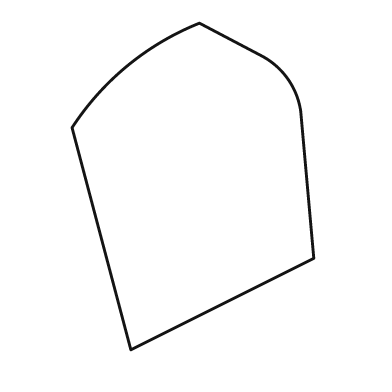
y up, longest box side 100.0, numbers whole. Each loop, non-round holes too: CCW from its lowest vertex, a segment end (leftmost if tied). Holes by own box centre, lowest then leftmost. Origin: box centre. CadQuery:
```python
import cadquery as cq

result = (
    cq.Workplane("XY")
    .moveTo(-19.0, -50.0)
    .lineTo(37.0, -22.0)
    .lineTo(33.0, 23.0)
    .threePointArc((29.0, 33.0), (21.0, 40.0))
    .lineTo(2.0, 50.0)
    .threePointArc((-20.0, 37.0), (-37.0, 18.0))
    .close()
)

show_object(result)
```